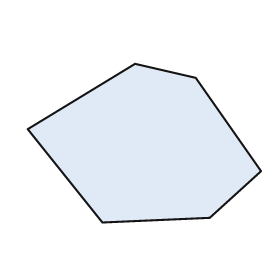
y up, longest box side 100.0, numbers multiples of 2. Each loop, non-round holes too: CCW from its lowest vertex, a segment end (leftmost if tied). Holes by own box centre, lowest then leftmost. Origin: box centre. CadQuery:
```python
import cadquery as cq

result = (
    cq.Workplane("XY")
    .moveTo(-18.0, -34.0)
    .lineTo(28.0, -32.0)
    .lineTo(50.0, -12.0)
    .lineTo(22.0, 28.0)
    .lineTo(-4.0, 34.0)
    .lineTo(-50.0, 6.0)
    .close()
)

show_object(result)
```